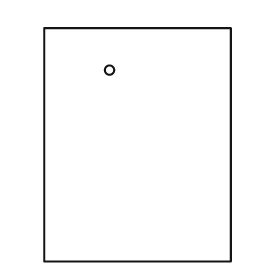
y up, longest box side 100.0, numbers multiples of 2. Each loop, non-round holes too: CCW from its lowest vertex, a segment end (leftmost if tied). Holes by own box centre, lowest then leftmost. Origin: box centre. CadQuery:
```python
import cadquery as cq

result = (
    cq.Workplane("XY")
    .moveTo(-40.0, -50.0)
    .lineTo(40.0, -50.0)
    .lineTo(40.0, 50.0)
    .lineTo(-40.0, 50.0)
    .close()
    .moveTo(-12.0, 32.0)
    .circle(2.0)
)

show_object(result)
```